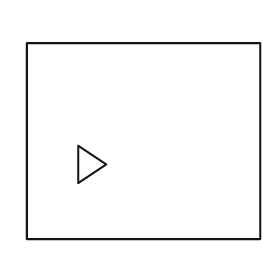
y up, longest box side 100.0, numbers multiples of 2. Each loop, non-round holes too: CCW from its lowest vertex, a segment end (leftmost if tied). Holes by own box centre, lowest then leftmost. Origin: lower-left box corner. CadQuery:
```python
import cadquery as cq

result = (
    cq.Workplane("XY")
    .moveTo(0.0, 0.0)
    .lineTo(100.0, 0.0)
    .lineTo(100.0, 84.0)
    .lineTo(0.0, 84.0)
    .close()
    .moveTo(22.0, 24.0)
    .lineTo(34.0, 32.0)
    .lineTo(22.0, 40.0)
    .close()
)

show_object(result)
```